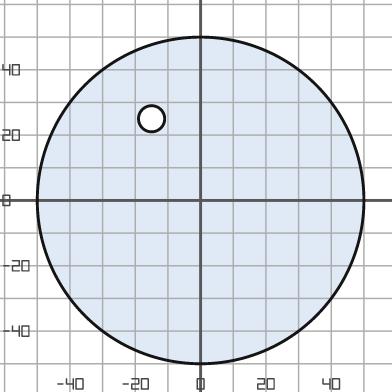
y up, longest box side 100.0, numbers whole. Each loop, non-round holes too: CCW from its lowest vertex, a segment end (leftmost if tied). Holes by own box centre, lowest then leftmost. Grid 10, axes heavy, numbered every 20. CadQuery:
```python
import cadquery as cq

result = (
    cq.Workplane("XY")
    .moveTo(0.0, 0.0)
    .circle(50.0)
    .moveTo(-15.0, 25.0)
    .circle(4.0)
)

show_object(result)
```